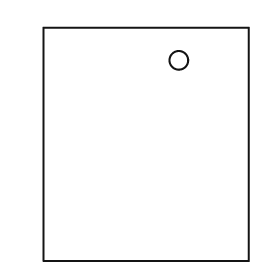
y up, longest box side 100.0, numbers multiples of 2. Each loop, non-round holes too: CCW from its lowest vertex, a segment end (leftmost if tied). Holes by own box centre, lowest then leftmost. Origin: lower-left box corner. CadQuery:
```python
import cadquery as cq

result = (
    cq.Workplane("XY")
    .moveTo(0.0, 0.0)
    .lineTo(88.0, 0.0)
    .lineTo(88.0, 100.0)
    .lineTo(0.0, 100.0)
    .close()
    .moveTo(58.0, 86.0)
    .circle(4.0)
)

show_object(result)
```